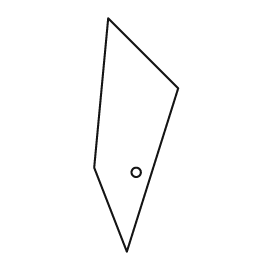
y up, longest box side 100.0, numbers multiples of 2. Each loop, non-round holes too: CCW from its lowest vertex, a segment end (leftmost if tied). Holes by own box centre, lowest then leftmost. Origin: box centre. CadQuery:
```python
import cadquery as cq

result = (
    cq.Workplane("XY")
    .moveTo(-4.0, -50.0)
    .lineTo(18.0, 20.0)
    .lineTo(-12.0, 50.0)
    .lineTo(-18.0, -14.0)
    .close()
    .moveTo(0.0, -16.0)
    .circle(2.0)
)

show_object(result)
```